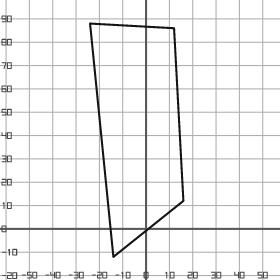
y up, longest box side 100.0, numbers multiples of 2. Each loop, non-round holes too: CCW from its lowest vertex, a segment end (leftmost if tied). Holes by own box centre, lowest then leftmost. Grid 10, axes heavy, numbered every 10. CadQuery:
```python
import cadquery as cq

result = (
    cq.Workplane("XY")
    .moveTo(-14.0, -12.0)
    .lineTo(16.0, 12.0)
    .lineTo(12.0, 86.0)
    .lineTo(-24.0, 88.0)
    .close()
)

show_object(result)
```